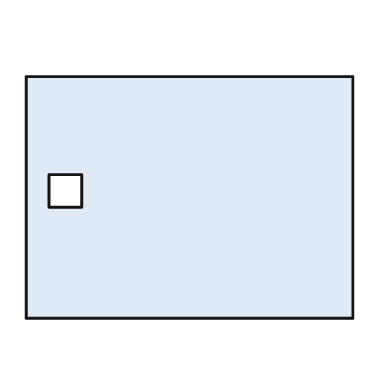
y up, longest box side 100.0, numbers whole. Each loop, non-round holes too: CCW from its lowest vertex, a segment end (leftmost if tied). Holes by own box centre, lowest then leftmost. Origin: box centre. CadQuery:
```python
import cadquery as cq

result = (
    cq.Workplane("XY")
    .moveTo(-50.0, -37.0)
    .lineTo(50.0, -37.0)
    .lineTo(50.0, 37.0)
    .lineTo(-50.0, 37.0)
    .close()
    .moveTo(-43.0, -3.0)
    .lineTo(-33.0, -3.0)
    .lineTo(-33.0, 7.0)
    .lineTo(-43.0, 7.0)
    .close()
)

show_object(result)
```